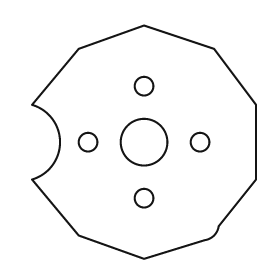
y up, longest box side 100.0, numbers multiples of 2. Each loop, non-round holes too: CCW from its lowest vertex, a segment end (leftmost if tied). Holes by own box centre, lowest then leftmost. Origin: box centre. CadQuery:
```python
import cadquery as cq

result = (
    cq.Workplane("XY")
    .moveTo(0.0, -50.0)
    .lineTo(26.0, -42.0)
    .threePointArc((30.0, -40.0), (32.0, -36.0))
    .lineTo(48.0, -16.0)
    .lineTo(48.0, 16.0)
    .lineTo(30.0, 40.0)
    .lineTo(0.0, 50.0)
    .lineTo(-28.0, 40.0)
    .lineTo(-48.0, 16.0)
    .threePointArc((-36.0, 0.0), (-48.0, -16.0))
    .lineTo(-28.0, -40.0)
    .close()
    .moveTo(0.0, -24.0)
    .circle(4.0)
    .moveTo(-24.0, 0.0)
    .circle(4.0)
    .moveTo(0.0, 0.0)
    .circle(10.0)
    .moveTo(24.0, 0.0)
    .circle(4.0)
    .moveTo(0.0, 24.0)
    .circle(4.0)
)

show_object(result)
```